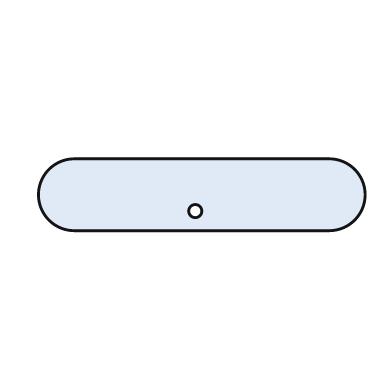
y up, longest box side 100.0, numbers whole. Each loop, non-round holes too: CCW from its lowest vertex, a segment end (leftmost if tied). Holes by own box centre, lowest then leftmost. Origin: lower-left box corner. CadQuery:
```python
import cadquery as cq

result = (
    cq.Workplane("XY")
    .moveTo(11.0, 0.0)
    .lineTo(89.0, 0.0)
    .threePointArc((100.0, 11.0), (89.0, 22.0))
    .lineTo(11.0, 22.0)
    .threePointArc((0.0, 11.0), (11.0, 0.0))
    .close()
    .moveTo(48.0, 6.0)
    .circle(2.0)
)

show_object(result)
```